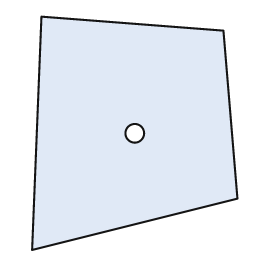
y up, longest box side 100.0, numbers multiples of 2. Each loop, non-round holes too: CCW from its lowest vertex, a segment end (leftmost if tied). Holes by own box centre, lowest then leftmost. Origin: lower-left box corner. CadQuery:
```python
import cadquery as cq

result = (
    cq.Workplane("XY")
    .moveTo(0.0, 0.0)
    .lineTo(88.0, 22.0)
    .lineTo(82.0, 94.0)
    .lineTo(4.0, 100.0)
    .close()
    .moveTo(44.0, 50.0)
    .circle(4.0)
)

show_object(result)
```